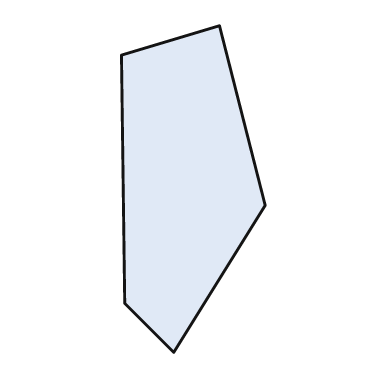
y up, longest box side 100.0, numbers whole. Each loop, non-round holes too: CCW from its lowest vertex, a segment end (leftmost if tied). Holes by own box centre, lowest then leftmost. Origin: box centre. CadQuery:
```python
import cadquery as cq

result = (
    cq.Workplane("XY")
    .moveTo(-6.0, -50.0)
    .lineTo(22.0, -5.0)
    .lineTo(8.0, 50.0)
    .lineTo(-22.0, 41.0)
    .lineTo(-21.0, -35.0)
    .close()
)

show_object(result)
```